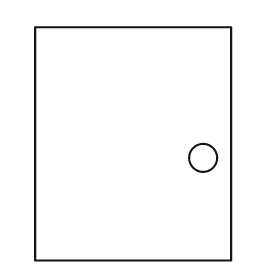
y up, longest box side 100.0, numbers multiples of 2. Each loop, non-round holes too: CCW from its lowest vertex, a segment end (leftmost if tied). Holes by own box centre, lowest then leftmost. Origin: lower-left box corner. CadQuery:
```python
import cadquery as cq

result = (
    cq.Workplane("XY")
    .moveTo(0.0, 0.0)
    .lineTo(84.0, 0.0)
    .lineTo(84.0, 100.0)
    .lineTo(0.0, 100.0)
    .close()
    .moveTo(72.0, 44.0)
    .circle(6.0)
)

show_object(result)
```